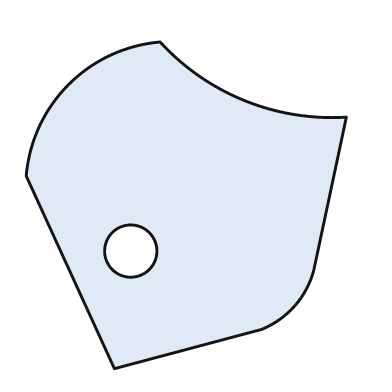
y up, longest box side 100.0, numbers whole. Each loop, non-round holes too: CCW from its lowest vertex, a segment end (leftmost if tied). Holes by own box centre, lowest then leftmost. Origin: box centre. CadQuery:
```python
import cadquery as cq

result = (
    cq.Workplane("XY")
    .moveTo(-22.0, -50.0)
    .lineTo(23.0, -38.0)
    .threePointArc((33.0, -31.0), (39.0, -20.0))
    .lineTo(49.0, 27.0)
    .threePointArc((18.0, 32.0), (-8.0, 50.0))
    .threePointArc((-36.0, 37.0), (-49.0, 9.0))
    .close()
    .moveTo(-17.0, -14.0)
    .circle(8.0)
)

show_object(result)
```